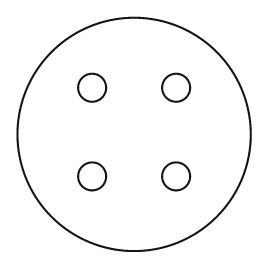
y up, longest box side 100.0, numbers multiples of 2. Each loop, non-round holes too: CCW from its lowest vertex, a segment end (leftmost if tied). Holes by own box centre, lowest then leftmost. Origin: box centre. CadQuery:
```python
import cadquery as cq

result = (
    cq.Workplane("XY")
    .moveTo(0.0, 0.0)
    .circle(50.0)
    .moveTo(-18.0, -18.0)
    .circle(6.0)
    .moveTo(18.0, -18.0)
    .circle(6.0)
    .moveTo(-18.0, 20.0)
    .circle(6.0)
    .moveTo(18.0, 20.0)
    .circle(6.0)
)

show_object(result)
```